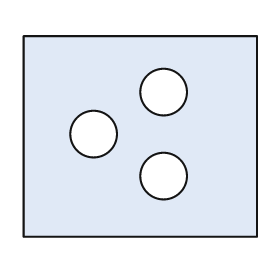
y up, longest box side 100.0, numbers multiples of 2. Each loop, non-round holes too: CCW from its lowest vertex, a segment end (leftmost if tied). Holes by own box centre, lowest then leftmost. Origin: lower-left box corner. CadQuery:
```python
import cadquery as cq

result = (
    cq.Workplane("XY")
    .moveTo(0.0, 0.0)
    .lineTo(100.0, 0.0)
    .lineTo(100.0, 86.0)
    .lineTo(0.0, 86.0)
    .close()
    .moveTo(60.0, 26.0)
    .circle(10.0)
    .moveTo(30.0, 44.0)
    .circle(10.0)
    .moveTo(60.0, 62.0)
    .circle(10.0)
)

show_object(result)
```